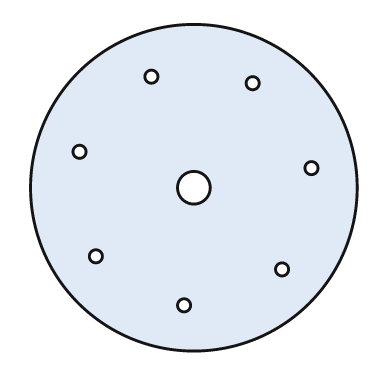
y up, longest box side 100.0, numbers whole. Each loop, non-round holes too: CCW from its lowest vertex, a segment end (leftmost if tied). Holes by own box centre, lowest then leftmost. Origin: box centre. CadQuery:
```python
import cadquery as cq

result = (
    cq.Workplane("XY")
    .moveTo(0.0, 0.0)
    .circle(50.0)
    .moveTo(-3.0, -36.0)
    .circle(2.0)
    .moveTo(27.0, -25.0)
    .circle(2.0)
    .moveTo(-30.0, -21.0)
    .circle(2.0)
    .moveTo(0.0, 0.0)
    .circle(5.0)
    .moveTo(36.0, 6.0)
    .circle(2.0)
    .moveTo(-35.0, 11.0)
    .circle(2.0)
    .moveTo(18.0, 32.0)
    .circle(2.0)
    .moveTo(-13.0, 34.0)
    .circle(2.0)
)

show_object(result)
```